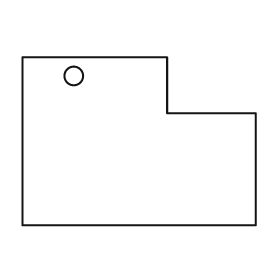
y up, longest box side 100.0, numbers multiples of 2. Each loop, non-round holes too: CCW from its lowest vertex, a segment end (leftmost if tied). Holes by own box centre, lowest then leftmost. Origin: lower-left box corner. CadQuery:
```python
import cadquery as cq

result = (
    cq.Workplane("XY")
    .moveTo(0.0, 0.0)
    .lineTo(100.0, 0.0)
    .lineTo(100.0, 48.0)
    .lineTo(62.0, 48.0)
    .lineTo(62.0, 72.0)
    .lineTo(0.0, 72.0)
    .close()
    .moveTo(22.0, 64.0)
    .circle(4.0)
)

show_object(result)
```